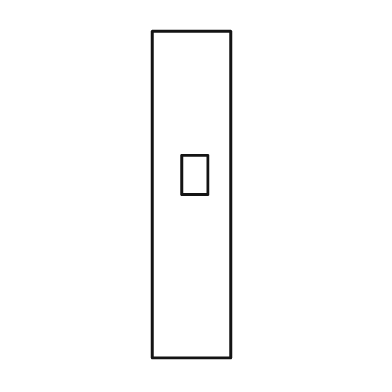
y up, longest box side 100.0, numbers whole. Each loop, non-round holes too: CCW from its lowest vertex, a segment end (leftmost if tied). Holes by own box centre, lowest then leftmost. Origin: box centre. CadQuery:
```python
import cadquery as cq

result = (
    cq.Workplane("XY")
    .moveTo(-12.0, -50.0)
    .lineTo(12.0, -50.0)
    .lineTo(12.0, 50.0)
    .lineTo(-12.0, 50.0)
    .close()
    .moveTo(-3.0, 0.0)
    .lineTo(5.0, 0.0)
    .lineTo(5.0, 12.0)
    .lineTo(-3.0, 12.0)
    .close()
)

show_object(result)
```